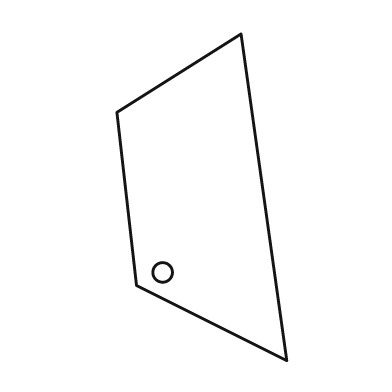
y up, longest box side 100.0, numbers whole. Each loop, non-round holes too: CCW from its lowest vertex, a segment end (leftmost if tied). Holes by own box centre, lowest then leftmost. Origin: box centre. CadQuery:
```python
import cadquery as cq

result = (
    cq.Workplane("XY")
    .moveTo(26.0, -50.0)
    .lineTo(12.0, 50.0)
    .lineTo(-26.0, 26.0)
    .lineTo(-20.0, -27.0)
    .close()
    .moveTo(-12.0, -23.0)
    .circle(3.0)
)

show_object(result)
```